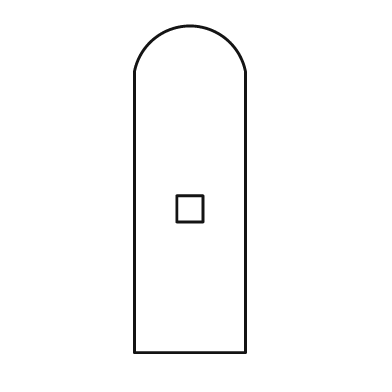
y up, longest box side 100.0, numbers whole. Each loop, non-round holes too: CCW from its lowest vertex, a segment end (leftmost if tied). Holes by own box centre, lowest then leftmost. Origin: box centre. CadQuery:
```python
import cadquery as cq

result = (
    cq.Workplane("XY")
    .moveTo(-17.0, -50.0)
    .lineTo(17.0, -50.0)
    .lineTo(17.0, 36.0)
    .threePointArc((0.0, 50.0), (-17.0, 36.0))
    .close()
    .moveTo(-4.0, -10.0)
    .lineTo(4.0, -10.0)
    .lineTo(4.0, -2.0)
    .lineTo(-4.0, -2.0)
    .close()
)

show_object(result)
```